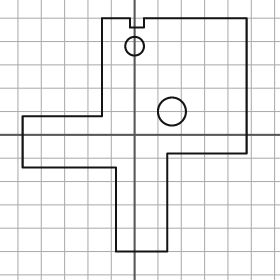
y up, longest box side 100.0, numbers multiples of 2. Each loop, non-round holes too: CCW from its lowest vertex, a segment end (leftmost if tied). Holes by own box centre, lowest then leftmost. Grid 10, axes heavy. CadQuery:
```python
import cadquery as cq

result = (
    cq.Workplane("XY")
    .moveTo(-8.0, -50.0)
    .lineTo(14.0, -50.0)
    .lineTo(14.0, -8.0)
    .lineTo(48.0, -8.0)
    .lineTo(48.0, 50.0)
    .lineTo(4.0, 50.0)
    .lineTo(4.0, 46.0)
    .lineTo(-2.0, 46.0)
    .lineTo(-2.0, 50.0)
    .lineTo(-14.0, 50.0)
    .lineTo(-14.0, 8.0)
    .lineTo(-48.0, 8.0)
    .lineTo(-48.0, -14.0)
    .lineTo(-8.0, -14.0)
    .close()
    .moveTo(16.0, 10.0)
    .circle(6.0)
    .moveTo(0.0, 38.0)
    .circle(4.0)
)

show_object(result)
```